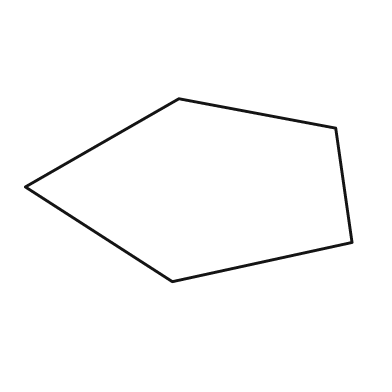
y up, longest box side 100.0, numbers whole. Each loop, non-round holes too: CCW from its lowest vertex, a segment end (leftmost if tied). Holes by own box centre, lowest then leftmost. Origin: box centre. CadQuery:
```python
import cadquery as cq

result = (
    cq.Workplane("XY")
    .moveTo(-5.0, -28.0)
    .lineTo(50.0, -16.0)
    .lineTo(45.0, 19.0)
    .lineTo(-3.0, 28.0)
    .lineTo(-50.0, 1.0)
    .close()
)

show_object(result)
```